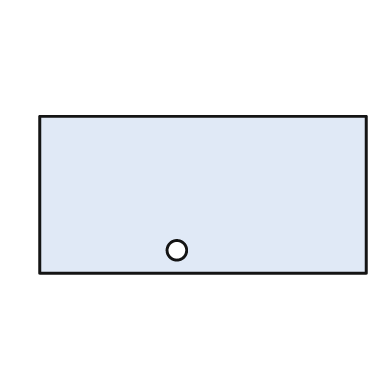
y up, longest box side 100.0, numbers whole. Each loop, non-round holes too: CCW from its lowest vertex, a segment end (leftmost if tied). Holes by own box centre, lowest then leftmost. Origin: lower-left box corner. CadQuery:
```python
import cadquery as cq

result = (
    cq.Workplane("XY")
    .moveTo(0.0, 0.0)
    .lineTo(100.0, 0.0)
    .lineTo(100.0, 48.0)
    .lineTo(0.0, 48.0)
    .close()
    .moveTo(42.0, 7.0)
    .circle(3.0)
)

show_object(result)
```